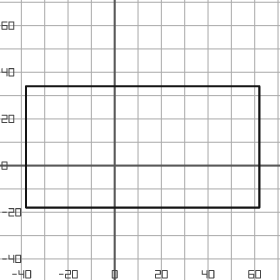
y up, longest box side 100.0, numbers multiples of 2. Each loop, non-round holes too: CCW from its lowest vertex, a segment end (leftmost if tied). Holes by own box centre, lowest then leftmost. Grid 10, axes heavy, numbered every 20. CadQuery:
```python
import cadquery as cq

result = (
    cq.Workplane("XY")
    .moveTo(-38.0, -18.0)
    .lineTo(62.0, -18.0)
    .lineTo(62.0, 34.0)
    .lineTo(-38.0, 34.0)
    .close()
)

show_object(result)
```